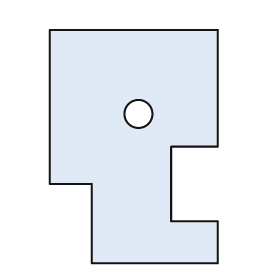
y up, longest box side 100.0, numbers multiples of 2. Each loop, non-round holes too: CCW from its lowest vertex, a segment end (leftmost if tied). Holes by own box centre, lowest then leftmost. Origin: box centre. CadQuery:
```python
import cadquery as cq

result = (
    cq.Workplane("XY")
    .moveTo(-18.0, -50.0)
    .lineTo(36.0, -50.0)
    .lineTo(36.0, -32.0)
    .lineTo(16.0, -32.0)
    .lineTo(16.0, 0.0)
    .lineTo(36.0, 0.0)
    .lineTo(36.0, 50.0)
    .lineTo(-36.0, 50.0)
    .lineTo(-36.0, -16.0)
    .lineTo(-18.0, -16.0)
    .close()
    .moveTo(2.0, 14.0)
    .circle(6.0)
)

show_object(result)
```